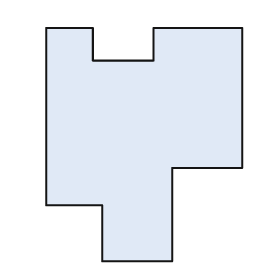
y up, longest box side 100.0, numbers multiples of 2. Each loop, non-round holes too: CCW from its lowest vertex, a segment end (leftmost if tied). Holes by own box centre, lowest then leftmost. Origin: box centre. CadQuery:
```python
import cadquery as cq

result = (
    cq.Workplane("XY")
    .moveTo(-18.0, -50.0)
    .lineTo(12.0, -50.0)
    .lineTo(12.0, -10.0)
    .lineTo(42.0, -10.0)
    .lineTo(42.0, 50.0)
    .lineTo(4.0, 50.0)
    .lineTo(4.0, 36.0)
    .lineTo(-22.0, 36.0)
    .lineTo(-22.0, 50.0)
    .lineTo(-42.0, 50.0)
    .lineTo(-42.0, -26.0)
    .lineTo(-18.0, -26.0)
    .close()
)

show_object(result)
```